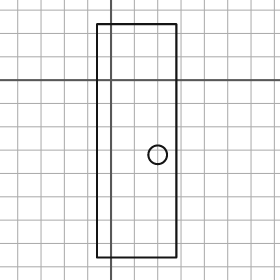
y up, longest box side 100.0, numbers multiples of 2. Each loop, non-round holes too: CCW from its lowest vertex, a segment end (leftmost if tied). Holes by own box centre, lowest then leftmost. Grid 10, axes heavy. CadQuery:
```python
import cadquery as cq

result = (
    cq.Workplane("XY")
    .moveTo(-6.0, -76.0)
    .lineTo(28.0, -76.0)
    .lineTo(28.0, 24.0)
    .lineTo(-6.0, 24.0)
    .close()
    .moveTo(20.0, -32.0)
    .circle(4.0)
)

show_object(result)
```